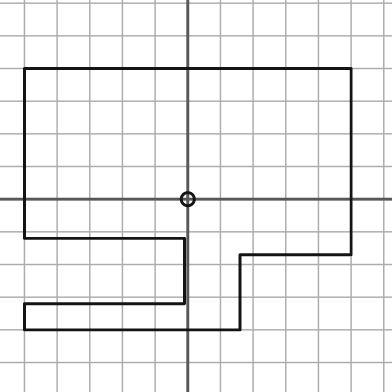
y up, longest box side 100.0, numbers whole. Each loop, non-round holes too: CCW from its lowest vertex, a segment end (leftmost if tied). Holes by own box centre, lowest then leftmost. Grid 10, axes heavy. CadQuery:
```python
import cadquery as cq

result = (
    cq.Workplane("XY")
    .moveTo(-50.0, -40.0)
    .lineTo(16.0, -40.0)
    .lineTo(16.0, -17.0)
    .lineTo(50.0, -17.0)
    .lineTo(50.0, 40.0)
    .lineTo(-50.0, 40.0)
    .lineTo(-50.0, -12.0)
    .lineTo(-1.0, -12.0)
    .lineTo(-1.0, -32.0)
    .lineTo(-50.0, -32.0)
    .close()
    .moveTo(0.0, 0.0)
    .circle(2.0)
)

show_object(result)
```